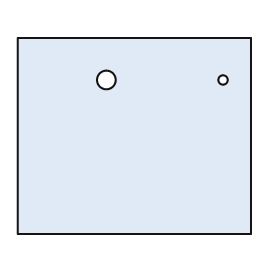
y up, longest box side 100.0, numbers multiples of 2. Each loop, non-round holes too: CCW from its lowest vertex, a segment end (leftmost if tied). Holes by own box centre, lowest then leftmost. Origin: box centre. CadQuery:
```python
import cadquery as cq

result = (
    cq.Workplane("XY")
    .moveTo(-50.0, -42.0)
    .lineTo(50.0, -42.0)
    .lineTo(50.0, 42.0)
    .lineTo(-50.0, 42.0)
    .close()
    .moveTo(-12.0, 24.0)
    .circle(4.0)
    .moveTo(38.0, 24.0)
    .circle(2.0)
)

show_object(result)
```